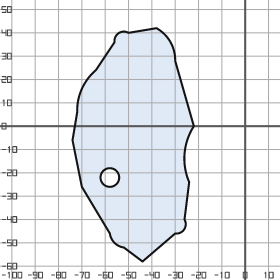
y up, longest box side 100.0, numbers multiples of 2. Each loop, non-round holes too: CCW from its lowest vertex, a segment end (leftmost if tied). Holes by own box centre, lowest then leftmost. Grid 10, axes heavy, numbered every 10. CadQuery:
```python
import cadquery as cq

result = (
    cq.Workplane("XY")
    .moveTo(-44.0, -58.0)
    .lineTo(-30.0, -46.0)
    .threePointArc((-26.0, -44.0), (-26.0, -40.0))
    .lineTo(-24.0, -24.0)
    .threePointArc((-26.0, -12.0), (-22.0, 0.0))
    .lineTo(-30.0, 28.0)
    .threePointArc((-32.0, 36.0), (-38.0, 42.0))
    .lineTo(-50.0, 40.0)
    .threePointArc((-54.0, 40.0), (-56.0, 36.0))
    .lineTo(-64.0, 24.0)
    .threePointArc((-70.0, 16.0), (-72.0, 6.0))
    .lineTo(-74.0, -6.0)
    .lineTo(-70.0, -26.0)
    .lineTo(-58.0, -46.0)
    .threePointArc((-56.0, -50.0), (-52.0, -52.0))
    .close()
    .moveTo(-58.0, -22.0)
    .circle(4.0)
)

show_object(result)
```